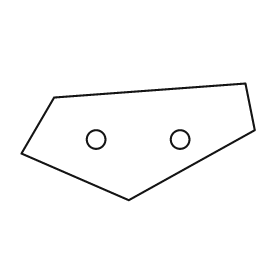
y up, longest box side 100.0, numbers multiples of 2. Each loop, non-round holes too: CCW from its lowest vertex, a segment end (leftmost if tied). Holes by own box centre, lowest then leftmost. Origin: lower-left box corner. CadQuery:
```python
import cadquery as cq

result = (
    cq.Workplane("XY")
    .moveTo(46.0, 0.0)
    .lineTo(100.0, 30.0)
    .lineTo(96.0, 50.0)
    .lineTo(14.0, 44.0)
    .lineTo(0.0, 20.0)
    .close()
    .moveTo(32.0, 26.0)
    .circle(4.0)
    .moveTo(68.0, 26.0)
    .circle(4.0)
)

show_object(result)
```